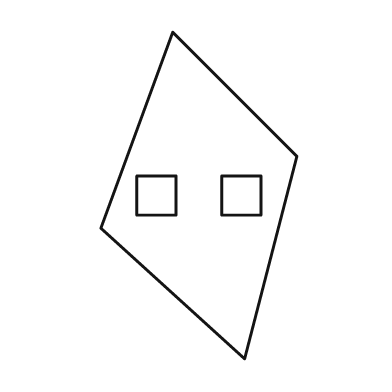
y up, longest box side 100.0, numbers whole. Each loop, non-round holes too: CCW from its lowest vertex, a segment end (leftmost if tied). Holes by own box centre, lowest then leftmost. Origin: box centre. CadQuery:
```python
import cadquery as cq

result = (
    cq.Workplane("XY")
    .moveTo(14.0, -50.0)
    .lineTo(30.0, 12.0)
    .lineTo(-8.0, 50.0)
    .lineTo(-30.0, -10.0)
    .close()
    .moveTo(-19.0, -6.0)
    .lineTo(-7.0, -6.0)
    .lineTo(-7.0, 6.0)
    .lineTo(-19.0, 6.0)
    .close()
    .moveTo(7.0, -6.0)
    .lineTo(19.0, -6.0)
    .lineTo(19.0, 6.0)
    .lineTo(7.0, 6.0)
    .close()
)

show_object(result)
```